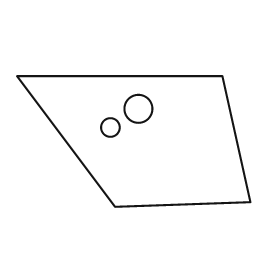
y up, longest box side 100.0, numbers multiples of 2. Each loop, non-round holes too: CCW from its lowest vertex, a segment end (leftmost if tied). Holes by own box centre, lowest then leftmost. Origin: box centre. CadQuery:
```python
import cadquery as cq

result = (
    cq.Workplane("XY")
    .moveTo(-8.0, -28.0)
    .lineTo(50.0, -26.0)
    .lineTo(38.0, 28.0)
    .lineTo(-50.0, 28.0)
    .close()
    .moveTo(-10.0, 6.0)
    .circle(4.0)
    .moveTo(2.0, 14.0)
    .circle(6.0)
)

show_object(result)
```